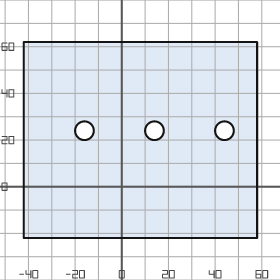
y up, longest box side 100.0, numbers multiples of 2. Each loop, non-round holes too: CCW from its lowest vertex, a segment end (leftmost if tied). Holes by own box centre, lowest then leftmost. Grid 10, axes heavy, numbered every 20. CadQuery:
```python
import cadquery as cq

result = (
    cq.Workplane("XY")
    .moveTo(-42.0, -22.0)
    .lineTo(58.0, -22.0)
    .lineTo(58.0, 62.0)
    .lineTo(-42.0, 62.0)
    .close()
    .moveTo(-16.0, 24.0)
    .circle(4.0)
    .moveTo(14.0, 24.0)
    .circle(4.0)
    .moveTo(44.0, 24.0)
    .circle(4.0)
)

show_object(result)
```